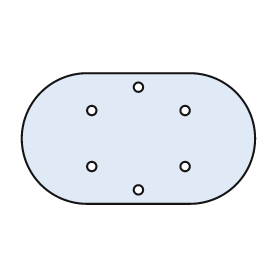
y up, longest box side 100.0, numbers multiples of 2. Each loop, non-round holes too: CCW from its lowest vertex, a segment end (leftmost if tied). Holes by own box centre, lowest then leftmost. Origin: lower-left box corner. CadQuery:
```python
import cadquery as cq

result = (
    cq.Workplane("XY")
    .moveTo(28.0, 0.0)
    .lineTo(72.0, 0.0)
    .threePointArc((100.0, 28.0), (72.0, 56.0))
    .lineTo(28.0, 56.0)
    .threePointArc((0.0, 28.0), (28.0, 0.0))
    .close()
    .moveTo(50.0, 6.0)
    .circle(2.0)
    .moveTo(30.0, 16.0)
    .circle(2.0)
    .moveTo(70.0, 16.0)
    .circle(2.0)
    .moveTo(30.0, 40.0)
    .circle(2.0)
    .moveTo(70.0, 40.0)
    .circle(2.0)
    .moveTo(50.0, 50.0)
    .circle(2.0)
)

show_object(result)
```